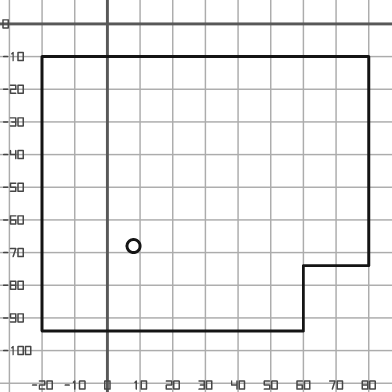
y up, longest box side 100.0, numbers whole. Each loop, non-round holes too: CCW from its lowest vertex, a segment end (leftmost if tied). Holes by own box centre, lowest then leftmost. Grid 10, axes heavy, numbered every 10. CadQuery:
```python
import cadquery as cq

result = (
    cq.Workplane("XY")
    .moveTo(-20.0, -94.0)
    .lineTo(60.0, -94.0)
    .lineTo(60.0, -74.0)
    .lineTo(80.0, -74.0)
    .lineTo(80.0, -10.0)
    .lineTo(-20.0, -10.0)
    .close()
    .moveTo(8.0, -68.0)
    .circle(2.0)
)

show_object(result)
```